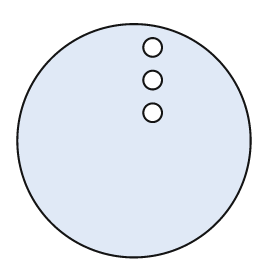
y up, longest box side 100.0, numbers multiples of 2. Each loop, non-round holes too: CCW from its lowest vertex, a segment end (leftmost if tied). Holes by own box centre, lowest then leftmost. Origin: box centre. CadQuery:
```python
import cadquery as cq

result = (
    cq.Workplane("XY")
    .moveTo(0.0, 0.0)
    .circle(50.0)
    .moveTo(8.0, 12.0)
    .circle(4.0)
    .moveTo(8.0, 26.0)
    .circle(4.0)
    .moveTo(8.0, 40.0)
    .circle(4.0)
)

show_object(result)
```